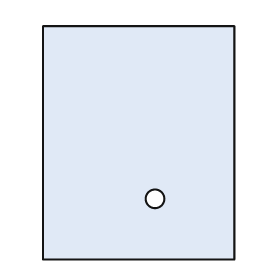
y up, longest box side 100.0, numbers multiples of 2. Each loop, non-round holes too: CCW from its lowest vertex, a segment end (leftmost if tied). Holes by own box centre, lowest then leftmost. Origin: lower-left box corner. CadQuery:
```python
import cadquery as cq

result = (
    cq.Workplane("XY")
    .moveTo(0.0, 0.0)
    .lineTo(82.0, 0.0)
    .lineTo(82.0, 100.0)
    .lineTo(0.0, 100.0)
    .close()
    .moveTo(48.0, 26.0)
    .circle(4.0)
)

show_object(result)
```